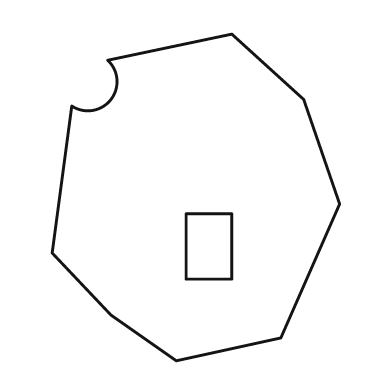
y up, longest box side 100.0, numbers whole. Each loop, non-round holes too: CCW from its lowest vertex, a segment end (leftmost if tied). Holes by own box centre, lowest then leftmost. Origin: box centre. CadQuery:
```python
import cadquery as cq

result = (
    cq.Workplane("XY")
    .moveTo(-6.0, -50.0)
    .lineTo(26.0, -43.0)
    .lineTo(44.0, -2.0)
    .lineTo(33.0, 30.0)
    .lineTo(11.0, 50.0)
    .lineTo(-27.0, 42.0)
    .threePointArc((-26.0, 30.0), (-38.0, 28.0))
    .lineTo(-44.0, -17.0)
    .lineTo(-26.0, -36.0)
    .close()
    .moveTo(-3.0, -25.0)
    .lineTo(11.0, -25.0)
    .lineTo(11.0, -5.0)
    .lineTo(-3.0, -5.0)
    .close()
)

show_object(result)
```